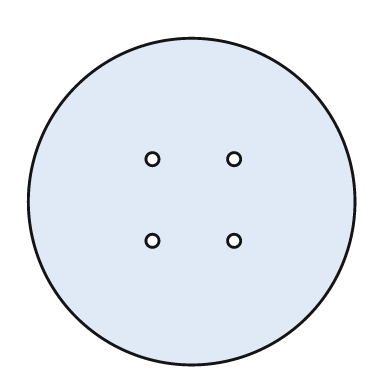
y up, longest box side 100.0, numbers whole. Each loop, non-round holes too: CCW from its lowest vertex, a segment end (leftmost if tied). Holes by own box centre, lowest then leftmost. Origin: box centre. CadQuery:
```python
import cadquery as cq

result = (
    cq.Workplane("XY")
    .moveTo(0.0, 0.0)
    .circle(50.0)
    .moveTo(-12.0, -12.0)
    .circle(2.0)
    .moveTo(13.0, -12.0)
    .circle(2.0)
    .moveTo(-12.0, 13.0)
    .circle(2.0)
    .moveTo(13.0, 13.0)
    .circle(2.0)
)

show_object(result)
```